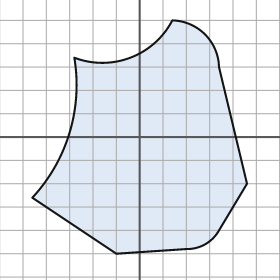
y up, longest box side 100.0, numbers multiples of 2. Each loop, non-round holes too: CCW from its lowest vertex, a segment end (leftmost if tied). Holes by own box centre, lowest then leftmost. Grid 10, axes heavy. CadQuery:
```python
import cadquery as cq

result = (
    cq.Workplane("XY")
    .moveTo(-10.0, -50.0)
    .lineTo(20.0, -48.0)
    .threePointArc((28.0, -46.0), (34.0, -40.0))
    .lineTo(46.0, -20.0)
    .lineTo(34.0, 30.0)
    .threePointArc((28.0, 44.0), (14.0, 50.0))
    .threePointArc((-4.0, 34.0), (-28.0, 34.0))
    .threePointArc((-30.0, 2.0), (-46.0, -26.0))
    .close()
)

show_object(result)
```